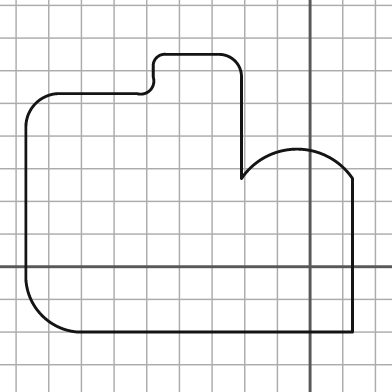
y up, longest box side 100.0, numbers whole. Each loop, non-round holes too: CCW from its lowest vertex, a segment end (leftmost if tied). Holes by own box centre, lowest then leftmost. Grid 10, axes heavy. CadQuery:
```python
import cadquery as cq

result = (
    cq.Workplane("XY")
    .moveTo(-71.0, -20.0)
    .lineTo(13.0, -20.0)
    .lineTo(13.0, 27.0)
    .threePointArc((-4.0, 36.0), (-21.0, 27.0))
    .lineTo(-21.0, 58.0)
    .threePointArc((-23.0, 63.0), (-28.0, 65.0))
    .lineTo(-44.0, 65.0)
    .threePointArc((-47.0, 64.0), (-48.0, 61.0))
    .lineTo(-48.0, 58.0)
    .threePointArc((-49.0, 54.0), (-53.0, 53.0))
    .lineTo(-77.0, 53.0)
    .threePointArc((-84.0, 50.0), (-87.0, 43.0))
    .lineTo(-87.0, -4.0)
    .threePointArc((-82.0, -15.0), (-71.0, -20.0))
    .close()
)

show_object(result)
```